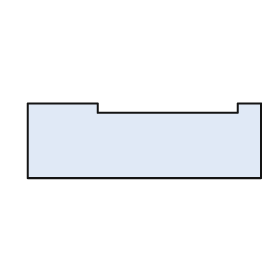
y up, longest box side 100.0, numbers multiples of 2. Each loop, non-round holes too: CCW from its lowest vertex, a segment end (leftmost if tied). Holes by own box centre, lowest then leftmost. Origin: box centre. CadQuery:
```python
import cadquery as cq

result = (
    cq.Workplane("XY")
    .moveTo(-50.0, -16.0)
    .lineTo(50.0, -16.0)
    .lineTo(50.0, 16.0)
    .lineTo(40.0, 16.0)
    .lineTo(40.0, 12.0)
    .lineTo(-20.0, 12.0)
    .lineTo(-20.0, 16.0)
    .lineTo(-50.0, 16.0)
    .close()
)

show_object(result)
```